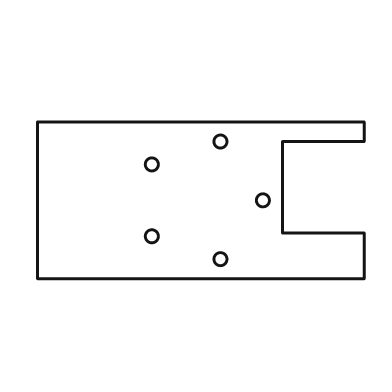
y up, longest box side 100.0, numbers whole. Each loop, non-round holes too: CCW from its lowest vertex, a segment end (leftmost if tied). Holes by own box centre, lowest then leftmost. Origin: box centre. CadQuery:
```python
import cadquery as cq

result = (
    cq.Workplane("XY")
    .moveTo(-50.0, -24.0)
    .lineTo(50.0, -24.0)
    .lineTo(50.0, -10.0)
    .lineTo(25.0, -10.0)
    .lineTo(25.0, 18.0)
    .lineTo(50.0, 18.0)
    .lineTo(50.0, 24.0)
    .lineTo(-50.0, 24.0)
    .close()
    .moveTo(6.0, -18.0)
    .circle(2.0)
    .moveTo(-15.0, -11.0)
    .circle(2.0)
    .moveTo(19.0, 0.0)
    .circle(2.0)
    .moveTo(-15.0, 11.0)
    .circle(2.0)
    .moveTo(6.0, 18.0)
    .circle(2.0)
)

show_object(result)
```